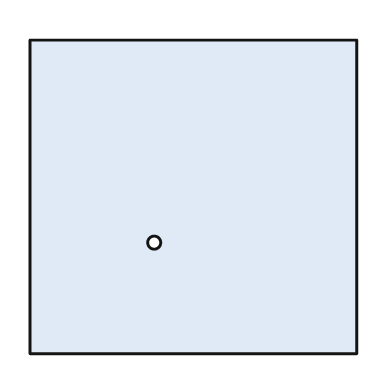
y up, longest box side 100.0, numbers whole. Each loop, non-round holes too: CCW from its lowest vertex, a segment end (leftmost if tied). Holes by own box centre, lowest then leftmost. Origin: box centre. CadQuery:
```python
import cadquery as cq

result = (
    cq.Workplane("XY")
    .moveTo(-50.0, -48.0)
    .lineTo(50.0, -48.0)
    .lineTo(50.0, 48.0)
    .lineTo(-50.0, 48.0)
    .close()
    .moveTo(-12.0, -14.0)
    .circle(2.0)
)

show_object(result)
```